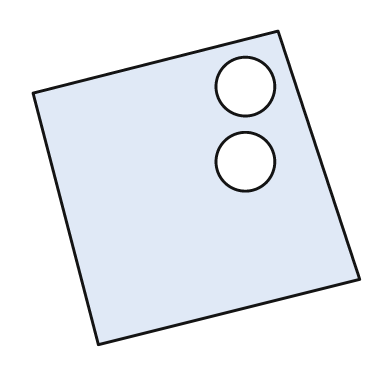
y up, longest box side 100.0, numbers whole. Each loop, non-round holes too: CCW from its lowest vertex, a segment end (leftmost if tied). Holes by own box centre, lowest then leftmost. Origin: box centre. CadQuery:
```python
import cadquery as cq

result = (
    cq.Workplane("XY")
    .moveTo(-30.0, -48.0)
    .lineTo(50.0, -28.0)
    .lineTo(25.0, 48.0)
    .lineTo(-50.0, 29.0)
    .close()
    .moveTo(15.0, 8.0)
    .circle(9.0)
    .moveTo(15.0, 31.0)
    .circle(9.0)
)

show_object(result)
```